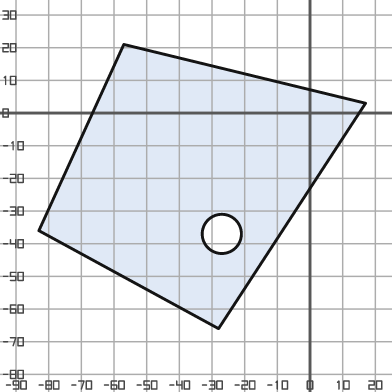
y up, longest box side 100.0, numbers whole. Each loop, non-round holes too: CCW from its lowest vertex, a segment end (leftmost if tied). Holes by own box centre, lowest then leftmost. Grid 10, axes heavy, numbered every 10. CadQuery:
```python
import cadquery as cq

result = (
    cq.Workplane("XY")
    .moveTo(-28.0, -66.0)
    .lineTo(17.0, 3.0)
    .lineTo(-57.0, 21.0)
    .lineTo(-83.0, -36.0)
    .close()
    .moveTo(-27.0, -37.0)
    .circle(6.0)
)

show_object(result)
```